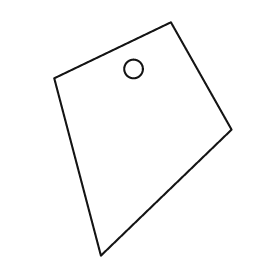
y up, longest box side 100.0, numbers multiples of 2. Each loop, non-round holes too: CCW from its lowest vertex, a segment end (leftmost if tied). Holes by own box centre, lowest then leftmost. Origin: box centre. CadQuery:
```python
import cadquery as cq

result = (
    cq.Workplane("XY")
    .moveTo(-18.0, -50.0)
    .lineTo(38.0, 4.0)
    .lineTo(12.0, 50.0)
    .lineTo(-38.0, 26.0)
    .close()
    .moveTo(-4.0, 30.0)
    .circle(4.0)
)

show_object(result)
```